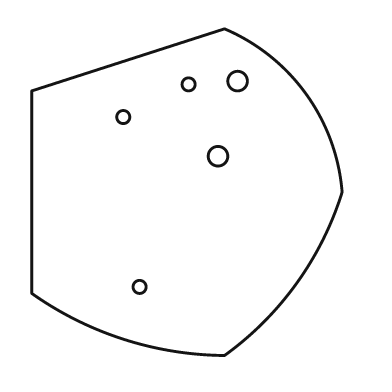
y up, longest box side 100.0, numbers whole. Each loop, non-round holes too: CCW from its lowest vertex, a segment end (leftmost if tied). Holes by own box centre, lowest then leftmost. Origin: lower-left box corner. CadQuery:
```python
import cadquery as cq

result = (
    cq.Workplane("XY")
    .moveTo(59.0, 0.0)
    .threePointArc((81.0, 22.0), (95.0, 50.0))
    .threePointArc((84.0, 80.0), (59.0, 100.0))
    .lineTo(0.0, 81.0)
    .lineTo(0.0, 19.0)
    .threePointArc((28.0, 5.0), (59.0, 0.0))
    .close()
    .moveTo(33.0, 21.0)
    .circle(2.0)
    .moveTo(57.0, 61.0)
    .circle(3.0)
    .moveTo(28.0, 73.0)
    .circle(2.0)
    .moveTo(48.0, 83.0)
    .circle(2.0)
    .moveTo(63.0, 84.0)
    .circle(3.0)
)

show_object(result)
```